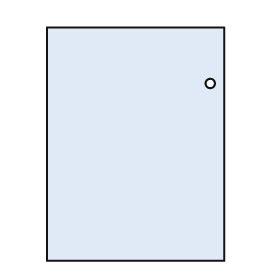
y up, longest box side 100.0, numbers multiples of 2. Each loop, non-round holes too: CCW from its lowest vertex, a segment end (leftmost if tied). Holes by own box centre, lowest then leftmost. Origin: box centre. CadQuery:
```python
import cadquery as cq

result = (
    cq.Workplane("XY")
    .moveTo(-38.0, -50.0)
    .lineTo(38.0, -50.0)
    .lineTo(38.0, 50.0)
    .lineTo(-38.0, 50.0)
    .close()
    .moveTo(32.0, 26.0)
    .circle(2.0)
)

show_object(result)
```